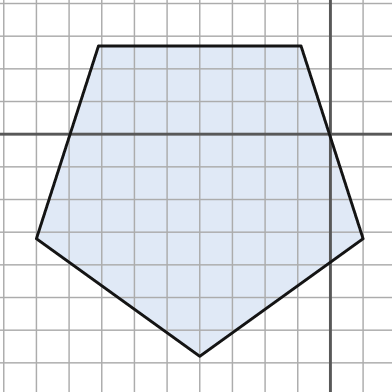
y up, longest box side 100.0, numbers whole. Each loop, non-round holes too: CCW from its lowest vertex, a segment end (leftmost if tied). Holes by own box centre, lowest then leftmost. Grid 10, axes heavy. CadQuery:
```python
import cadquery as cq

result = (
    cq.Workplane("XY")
    .moveTo(-40.0, -68.0)
    .lineTo(10.0, -32.0)
    .lineTo(-9.0, 27.0)
    .lineTo(-71.0, 27.0)
    .lineTo(-90.0, -32.0)
    .close()
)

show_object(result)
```